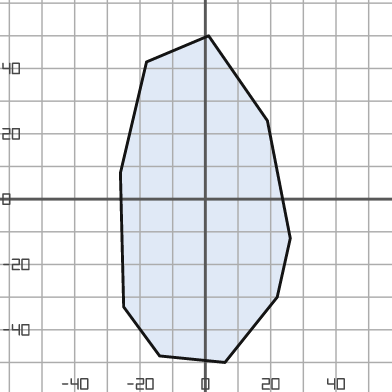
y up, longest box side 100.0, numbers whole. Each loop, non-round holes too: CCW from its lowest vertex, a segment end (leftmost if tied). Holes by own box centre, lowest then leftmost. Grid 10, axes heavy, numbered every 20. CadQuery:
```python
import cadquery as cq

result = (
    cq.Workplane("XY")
    .moveTo(6.0, -50.0)
    .lineTo(22.0, -30.0)
    .lineTo(26.0, -12.0)
    .lineTo(19.0, 24.0)
    .lineTo(1.0, 50.0)
    .lineTo(-18.0, 42.0)
    .lineTo(-26.0, 8.0)
    .lineTo(-25.0, -33.0)
    .lineTo(-14.0, -48.0)
    .close()
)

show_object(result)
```